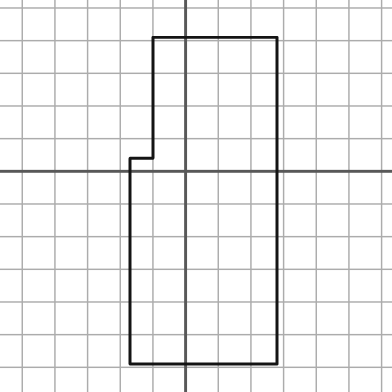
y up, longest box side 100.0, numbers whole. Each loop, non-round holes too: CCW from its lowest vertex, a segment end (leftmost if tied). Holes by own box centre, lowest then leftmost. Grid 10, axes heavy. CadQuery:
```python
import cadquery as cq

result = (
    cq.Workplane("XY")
    .moveTo(-17.0, -59.0)
    .lineTo(28.0, -59.0)
    .lineTo(28.0, 41.0)
    .lineTo(-10.0, 41.0)
    .lineTo(-10.0, 4.0)
    .lineTo(-17.0, 4.0)
    .close()
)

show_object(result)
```